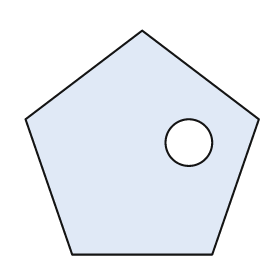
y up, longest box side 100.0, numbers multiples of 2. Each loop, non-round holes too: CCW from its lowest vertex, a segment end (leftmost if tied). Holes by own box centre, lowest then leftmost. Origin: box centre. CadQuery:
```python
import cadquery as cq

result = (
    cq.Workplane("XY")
    .moveTo(-30.0, -48.0)
    .lineTo(30.0, -48.0)
    .lineTo(50.0, 10.0)
    .lineTo(0.0, 48.0)
    .lineTo(-50.0, 10.0)
    .close()
    .moveTo(20.0, 0.0)
    .circle(10.0)
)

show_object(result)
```